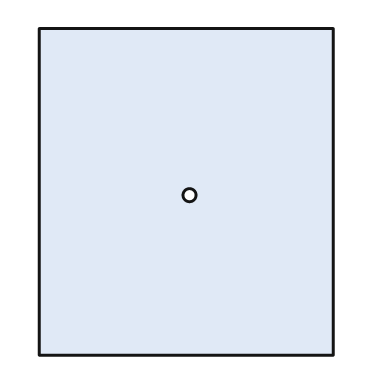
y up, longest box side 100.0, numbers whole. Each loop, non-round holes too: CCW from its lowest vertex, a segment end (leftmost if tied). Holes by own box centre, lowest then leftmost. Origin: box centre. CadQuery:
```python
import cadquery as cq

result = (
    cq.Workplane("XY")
    .moveTo(-45.0, -50.0)
    .lineTo(45.0, -50.0)
    .lineTo(45.0, 50.0)
    .lineTo(-45.0, 50.0)
    .close()
    .moveTo(1.0, -1.0)
    .circle(2.0)
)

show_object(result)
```